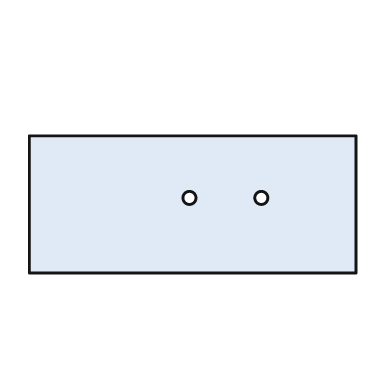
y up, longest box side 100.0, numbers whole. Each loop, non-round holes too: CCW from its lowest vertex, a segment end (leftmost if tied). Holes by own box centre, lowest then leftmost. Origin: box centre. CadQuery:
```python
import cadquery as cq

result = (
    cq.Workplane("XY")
    .moveTo(-50.0, -21.0)
    .lineTo(50.0, -21.0)
    .lineTo(50.0, 21.0)
    .lineTo(-50.0, 21.0)
    .close()
    .moveTo(-1.0, 2.0)
    .circle(2.0)
    .moveTo(21.0, 2.0)
    .circle(2.0)
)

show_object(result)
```